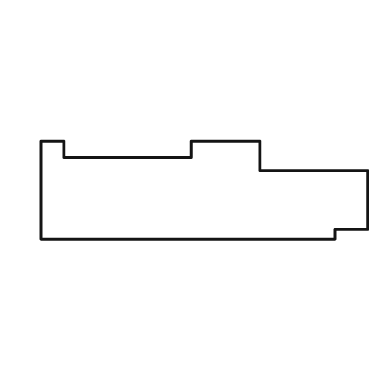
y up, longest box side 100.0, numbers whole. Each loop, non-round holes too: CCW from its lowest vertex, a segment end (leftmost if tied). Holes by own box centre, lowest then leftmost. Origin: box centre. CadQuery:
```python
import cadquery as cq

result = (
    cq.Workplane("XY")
    .moveTo(-50.0, -15.0)
    .lineTo(40.0, -15.0)
    .lineTo(40.0, -12.0)
    .lineTo(50.0, -12.0)
    .lineTo(50.0, 6.0)
    .lineTo(17.0, 6.0)
    .lineTo(17.0, 15.0)
    .lineTo(-4.0, 15.0)
    .lineTo(-4.0, 10.0)
    .lineTo(-43.0, 10.0)
    .lineTo(-43.0, 15.0)
    .lineTo(-50.0, 15.0)
    .close()
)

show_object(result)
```